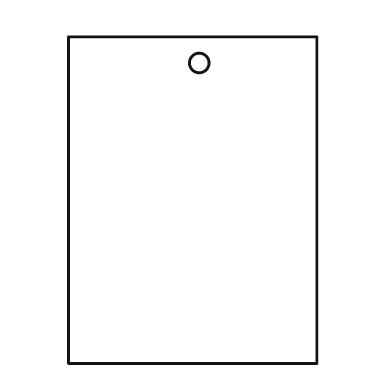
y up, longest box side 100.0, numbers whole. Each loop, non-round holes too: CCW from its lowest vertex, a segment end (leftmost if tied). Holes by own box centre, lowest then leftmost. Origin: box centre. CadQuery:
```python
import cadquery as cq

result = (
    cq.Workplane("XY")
    .moveTo(-38.0, -50.0)
    .lineTo(38.0, -50.0)
    .lineTo(38.0, 50.0)
    .lineTo(-38.0, 50.0)
    .close()
    .moveTo(2.0, 42.0)
    .circle(3.0)
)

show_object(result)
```